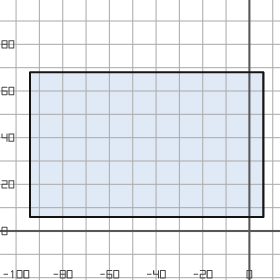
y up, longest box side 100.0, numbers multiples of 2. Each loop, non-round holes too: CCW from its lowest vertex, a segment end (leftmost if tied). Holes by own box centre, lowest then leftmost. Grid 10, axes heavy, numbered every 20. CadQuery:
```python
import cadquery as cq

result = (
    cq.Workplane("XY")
    .moveTo(-94.0, 6.0)
    .lineTo(6.0, 6.0)
    .lineTo(6.0, 68.0)
    .lineTo(-94.0, 68.0)
    .close()
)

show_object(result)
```